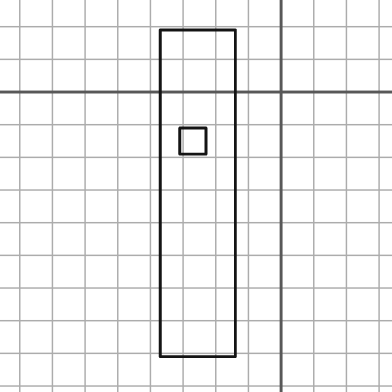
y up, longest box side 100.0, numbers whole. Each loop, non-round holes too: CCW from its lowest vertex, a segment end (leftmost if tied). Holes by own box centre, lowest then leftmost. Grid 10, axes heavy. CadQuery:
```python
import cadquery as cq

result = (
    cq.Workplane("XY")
    .moveTo(-37.0, -81.0)
    .lineTo(-14.0, -81.0)
    .lineTo(-14.0, 19.0)
    .lineTo(-37.0, 19.0)
    .close()
    .moveTo(-31.0, -19.0)
    .lineTo(-23.0, -19.0)
    .lineTo(-23.0, -11.0)
    .lineTo(-31.0, -11.0)
    .close()
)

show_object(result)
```